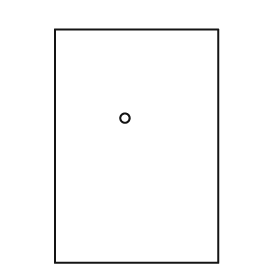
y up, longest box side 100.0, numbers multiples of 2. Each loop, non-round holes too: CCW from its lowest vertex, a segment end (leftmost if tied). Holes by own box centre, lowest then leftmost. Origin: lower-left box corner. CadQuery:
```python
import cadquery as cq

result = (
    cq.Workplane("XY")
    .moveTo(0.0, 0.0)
    .lineTo(70.0, 0.0)
    .lineTo(70.0, 100.0)
    .lineTo(0.0, 100.0)
    .close()
    .moveTo(30.0, 62.0)
    .circle(2.0)
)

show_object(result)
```